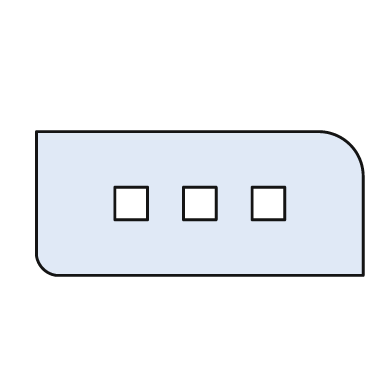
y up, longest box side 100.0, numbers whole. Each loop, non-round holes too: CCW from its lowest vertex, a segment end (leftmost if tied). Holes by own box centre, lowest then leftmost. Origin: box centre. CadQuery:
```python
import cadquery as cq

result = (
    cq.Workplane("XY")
    .moveTo(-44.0, -22.0)
    .lineTo(50.0, -22.0)
    .lineTo(50.0, 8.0)
    .threePointArc((46.0, 18.0), (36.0, 22.0))
    .lineTo(-50.0, 22.0)
    .lineTo(-50.0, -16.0)
    .threePointArc((-48.0, -20.0), (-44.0, -22.0))
    .close()
    .moveTo(-26.0, -5.0)
    .lineTo(-16.0, -5.0)
    .lineTo(-16.0, 5.0)
    .lineTo(-26.0, 5.0)
    .close()
    .moveTo(-5.0, -5.0)
    .lineTo(5.0, -5.0)
    .lineTo(5.0, 5.0)
    .lineTo(-5.0, 5.0)
    .close()
    .moveTo(16.0, -5.0)
    .lineTo(26.0, -5.0)
    .lineTo(26.0, 5.0)
    .lineTo(16.0, 5.0)
    .close()
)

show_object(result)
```